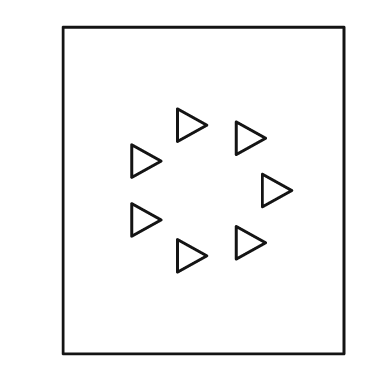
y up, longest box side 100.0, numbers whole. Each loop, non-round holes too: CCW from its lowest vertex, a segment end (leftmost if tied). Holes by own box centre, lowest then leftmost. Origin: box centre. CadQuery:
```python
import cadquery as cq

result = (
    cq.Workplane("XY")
    .moveTo(-43.0, -50.0)
    .lineTo(43.0, -50.0)
    .lineTo(43.0, 50.0)
    .lineTo(-43.0, 50.0)
    .close()
    .moveTo(-8.0, -25.0)
    .lineTo(1.0, -20.0)
    .lineTo(-8.0, -15.0)
    .close()
    .moveTo(10.0, -21.0)
    .lineTo(19.0, -16.0)
    .lineTo(10.0, -11.0)
    .close()
    .moveTo(-22.0, -14.0)
    .lineTo(-13.0, -9.0)
    .lineTo(-22.0, -4.0)
    .close()
    .moveTo(18.0, -5.0)
    .lineTo(27.0, 0.0)
    .lineTo(18.0, 5.0)
    .close()
    .moveTo(-22.0, 4.0)
    .lineTo(-13.0, 9.0)
    .lineTo(-22.0, 14.0)
    .close()
    .moveTo(10.0, 11.0)
    .lineTo(19.0, 16.0)
    .lineTo(10.0, 21.0)
    .close()
    .moveTo(-8.0, 15.0)
    .lineTo(1.0, 20.0)
    .lineTo(-8.0, 25.0)
    .close()
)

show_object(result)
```